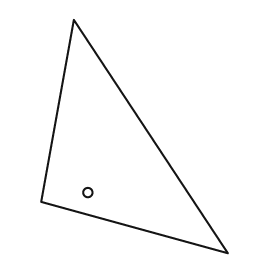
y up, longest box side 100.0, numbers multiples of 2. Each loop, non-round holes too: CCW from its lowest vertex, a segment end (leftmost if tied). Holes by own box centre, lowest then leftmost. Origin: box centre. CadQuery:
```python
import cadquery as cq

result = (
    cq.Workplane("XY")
    .moveTo(40.0, -50.0)
    .lineTo(-26.0, 50.0)
    .lineTo(-40.0, -28.0)
    .close()
    .moveTo(-20.0, -24.0)
    .circle(2.0)
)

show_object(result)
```